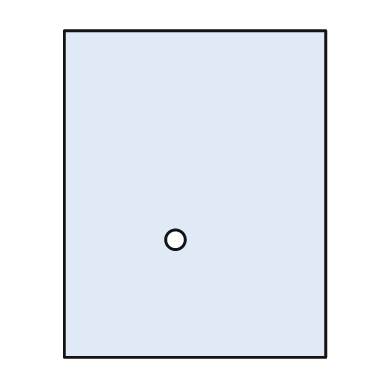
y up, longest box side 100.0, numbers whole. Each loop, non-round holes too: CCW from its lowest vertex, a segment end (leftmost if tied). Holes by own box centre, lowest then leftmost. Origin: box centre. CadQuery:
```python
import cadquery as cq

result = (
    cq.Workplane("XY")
    .moveTo(-40.0, -50.0)
    .lineTo(40.0, -50.0)
    .lineTo(40.0, 50.0)
    .lineTo(-40.0, 50.0)
    .close()
    .moveTo(-6.0, -14.0)
    .circle(3.0)
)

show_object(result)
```